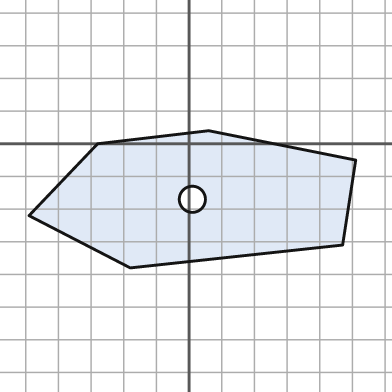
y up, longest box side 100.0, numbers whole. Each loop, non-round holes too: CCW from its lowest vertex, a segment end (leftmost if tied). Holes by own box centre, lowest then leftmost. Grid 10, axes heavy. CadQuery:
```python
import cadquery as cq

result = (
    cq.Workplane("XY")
    .moveTo(-18.0, -38.0)
    .lineTo(47.0, -31.0)
    .lineTo(51.0, -5.0)
    .lineTo(6.0, 4.0)
    .lineTo(-28.0, 0.0)
    .lineTo(-49.0, -22.0)
    .close()
    .moveTo(1.0, -17.0)
    .circle(4.0)
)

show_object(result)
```